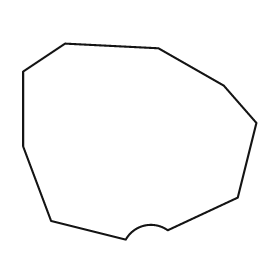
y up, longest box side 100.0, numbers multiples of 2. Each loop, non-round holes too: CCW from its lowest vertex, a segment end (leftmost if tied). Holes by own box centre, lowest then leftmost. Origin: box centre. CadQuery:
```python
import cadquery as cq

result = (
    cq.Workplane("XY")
    .moveTo(-6.0, -42.0)
    .threePointArc((2.0, -36.0), (12.0, -38.0))
    .lineTo(42.0, -24.0)
    .lineTo(50.0, 8.0)
    .lineTo(36.0, 24.0)
    .lineTo(8.0, 40.0)
    .lineTo(-32.0, 42.0)
    .lineTo(-50.0, 30.0)
    .lineTo(-50.0, -2.0)
    .lineTo(-38.0, -34.0)
    .close()
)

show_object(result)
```